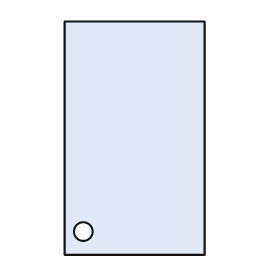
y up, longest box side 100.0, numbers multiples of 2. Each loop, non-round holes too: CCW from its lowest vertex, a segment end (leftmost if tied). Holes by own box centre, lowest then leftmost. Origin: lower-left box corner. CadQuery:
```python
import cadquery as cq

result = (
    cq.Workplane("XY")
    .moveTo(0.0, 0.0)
    .lineTo(60.0, 0.0)
    .lineTo(60.0, 100.0)
    .lineTo(0.0, 100.0)
    .close()
    .moveTo(8.0, 10.0)
    .circle(4.0)
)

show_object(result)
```